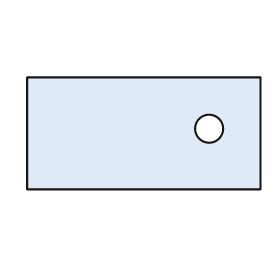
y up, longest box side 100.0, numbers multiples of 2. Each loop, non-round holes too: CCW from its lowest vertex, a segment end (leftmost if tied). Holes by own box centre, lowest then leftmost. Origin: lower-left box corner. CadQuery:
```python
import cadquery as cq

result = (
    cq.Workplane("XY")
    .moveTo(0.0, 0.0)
    .lineTo(100.0, 0.0)
    .lineTo(100.0, 48.0)
    .lineTo(0.0, 48.0)
    .close()
    .moveTo(78.0, 26.0)
    .circle(6.0)
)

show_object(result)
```